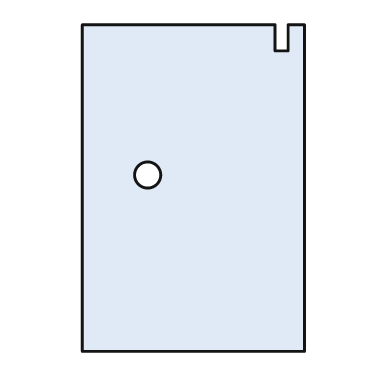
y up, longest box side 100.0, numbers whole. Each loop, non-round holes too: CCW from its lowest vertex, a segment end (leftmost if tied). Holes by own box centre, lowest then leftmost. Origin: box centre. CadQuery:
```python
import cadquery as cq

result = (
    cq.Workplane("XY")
    .moveTo(-34.0, -50.0)
    .lineTo(34.0, -50.0)
    .lineTo(34.0, 50.0)
    .lineTo(29.0, 50.0)
    .lineTo(29.0, 42.0)
    .lineTo(25.0, 42.0)
    .lineTo(25.0, 50.0)
    .lineTo(-34.0, 50.0)
    .close()
    .moveTo(-14.0, 4.0)
    .circle(4.0)
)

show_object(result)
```